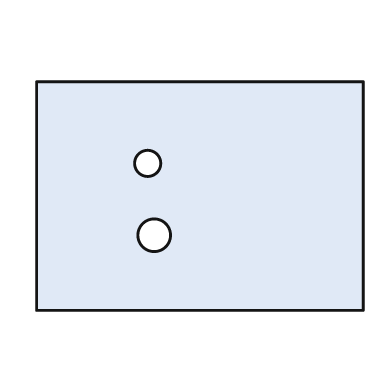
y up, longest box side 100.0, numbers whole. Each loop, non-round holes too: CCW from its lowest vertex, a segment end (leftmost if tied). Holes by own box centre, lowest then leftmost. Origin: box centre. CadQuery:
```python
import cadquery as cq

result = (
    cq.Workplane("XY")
    .moveTo(-50.0, -35.0)
    .lineTo(50.0, -35.0)
    .lineTo(50.0, 35.0)
    .lineTo(-50.0, 35.0)
    .close()
    .moveTo(-14.0, -12.0)
    .circle(5.0)
    .moveTo(-16.0, 10.0)
    .circle(4.0)
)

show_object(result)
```